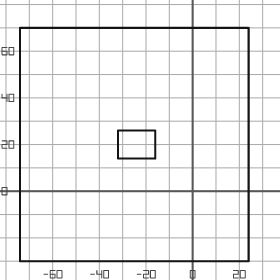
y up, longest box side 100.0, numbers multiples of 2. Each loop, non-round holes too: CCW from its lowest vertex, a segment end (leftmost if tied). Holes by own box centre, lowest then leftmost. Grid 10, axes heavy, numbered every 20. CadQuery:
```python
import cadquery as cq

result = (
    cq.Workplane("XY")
    .moveTo(-74.0, -30.0)
    .lineTo(24.0, -30.0)
    .lineTo(24.0, 70.0)
    .lineTo(-74.0, 70.0)
    .close()
    .moveTo(-32.0, 14.0)
    .lineTo(-16.0, 14.0)
    .lineTo(-16.0, 26.0)
    .lineTo(-32.0, 26.0)
    .close()
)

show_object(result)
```